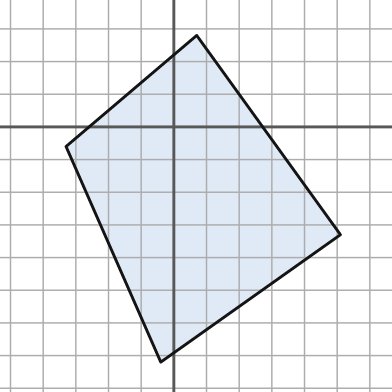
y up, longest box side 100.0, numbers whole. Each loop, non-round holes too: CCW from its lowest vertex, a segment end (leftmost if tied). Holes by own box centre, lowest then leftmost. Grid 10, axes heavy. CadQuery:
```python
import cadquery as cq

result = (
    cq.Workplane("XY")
    .moveTo(-4.0, -72.0)
    .lineTo(51.0, -33.0)
    .lineTo(7.0, 28.0)
    .lineTo(-33.0, -6.0)
    .close()
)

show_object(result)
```